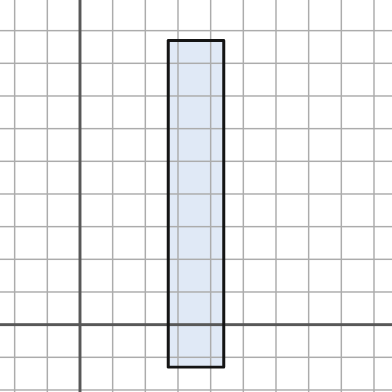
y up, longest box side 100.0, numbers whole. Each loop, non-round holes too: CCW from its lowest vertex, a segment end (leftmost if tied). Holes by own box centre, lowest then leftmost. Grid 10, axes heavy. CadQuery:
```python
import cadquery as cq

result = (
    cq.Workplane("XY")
    .moveTo(27.0, -13.0)
    .lineTo(44.0, -13.0)
    .lineTo(44.0, 87.0)
    .lineTo(27.0, 87.0)
    .close()
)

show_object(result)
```